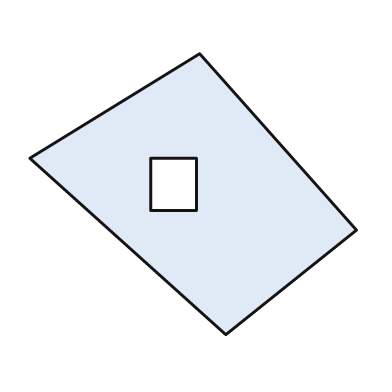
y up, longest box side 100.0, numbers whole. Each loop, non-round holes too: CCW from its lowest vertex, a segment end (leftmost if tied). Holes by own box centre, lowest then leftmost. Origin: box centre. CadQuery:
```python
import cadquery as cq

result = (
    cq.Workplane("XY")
    .moveTo(10.0, -43.0)
    .lineTo(50.0, -11.0)
    .lineTo(2.0, 43.0)
    .lineTo(-50.0, 11.0)
    .close()
    .moveTo(-13.0, -5.0)
    .lineTo(1.0, -5.0)
    .lineTo(1.0, 11.0)
    .lineTo(-13.0, 11.0)
    .close()
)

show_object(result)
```